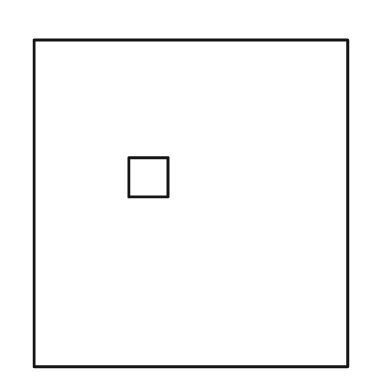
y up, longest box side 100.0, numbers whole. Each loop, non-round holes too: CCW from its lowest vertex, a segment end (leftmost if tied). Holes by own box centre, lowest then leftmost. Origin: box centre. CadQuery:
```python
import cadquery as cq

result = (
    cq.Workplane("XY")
    .moveTo(-48.0, -50.0)
    .lineTo(48.0, -50.0)
    .lineTo(48.0, 50.0)
    .lineTo(-48.0, 50.0)
    .close()
    .moveTo(-19.0, 2.0)
    .lineTo(-7.0, 2.0)
    .lineTo(-7.0, 14.0)
    .lineTo(-19.0, 14.0)
    .close()
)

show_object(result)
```